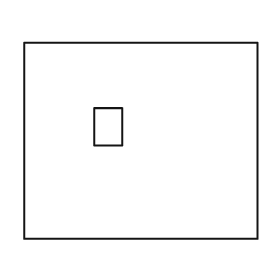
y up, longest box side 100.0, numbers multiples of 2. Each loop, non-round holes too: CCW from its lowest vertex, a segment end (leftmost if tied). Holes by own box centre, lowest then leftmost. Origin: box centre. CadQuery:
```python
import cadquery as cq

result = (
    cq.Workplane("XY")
    .moveTo(-50.0, -42.0)
    .lineTo(50.0, -42.0)
    .lineTo(50.0, 42.0)
    .lineTo(-50.0, 42.0)
    .close()
    .moveTo(-20.0, -2.0)
    .lineTo(-8.0, -2.0)
    .lineTo(-8.0, 14.0)
    .lineTo(-20.0, 14.0)
    .close()
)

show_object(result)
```